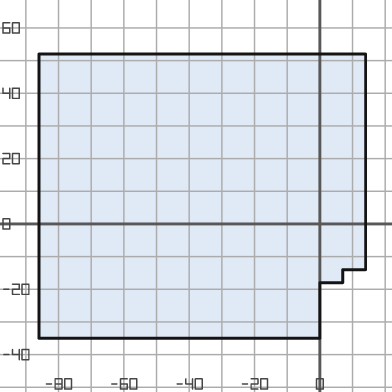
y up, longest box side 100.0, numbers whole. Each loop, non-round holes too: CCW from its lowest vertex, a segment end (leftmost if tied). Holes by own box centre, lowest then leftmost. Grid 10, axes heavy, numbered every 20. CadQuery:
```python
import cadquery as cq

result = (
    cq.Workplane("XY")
    .moveTo(-86.0, -35.0)
    .lineTo(0.0, -35.0)
    .lineTo(0.0, -18.0)
    .lineTo(7.0, -18.0)
    .lineTo(7.0, -14.0)
    .lineTo(14.0, -14.0)
    .lineTo(14.0, 52.0)
    .lineTo(-86.0, 52.0)
    .close()
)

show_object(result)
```